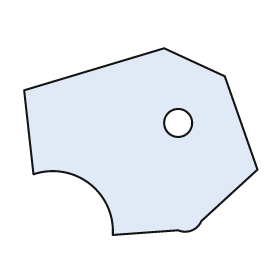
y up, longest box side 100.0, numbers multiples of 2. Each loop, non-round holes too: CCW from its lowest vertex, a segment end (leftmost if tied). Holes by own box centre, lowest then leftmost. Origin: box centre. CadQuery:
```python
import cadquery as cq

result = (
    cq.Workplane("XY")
    .moveTo(-12.0, -40.0)
    .lineTo(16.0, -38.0)
    .threePointArc((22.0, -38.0), (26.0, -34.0))
    .lineTo(50.0, -12.0)
    .lineTo(36.0, 28.0)
    .lineTo(10.0, 40.0)
    .lineTo(-50.0, 22.0)
    .lineTo(-46.0, -14.0)
    .threePointArc((-22.0, -18.0), (-12.0, -40.0))
    .close()
    .moveTo(16.0, 8.0)
    .circle(6.0)
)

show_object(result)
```